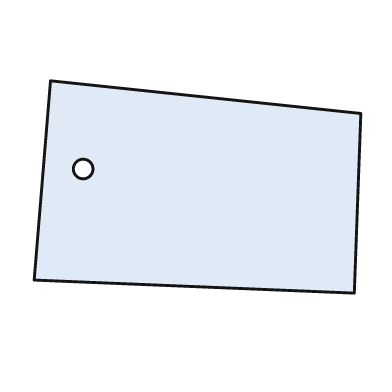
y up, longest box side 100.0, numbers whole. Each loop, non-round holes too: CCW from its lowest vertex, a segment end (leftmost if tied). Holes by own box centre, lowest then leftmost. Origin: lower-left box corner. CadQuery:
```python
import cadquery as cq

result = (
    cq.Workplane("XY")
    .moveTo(98.0, 0.0)
    .lineTo(100.0, 55.0)
    .lineTo(5.0, 65.0)
    .lineTo(0.0, 4.0)
    .close()
    .moveTo(15.0, 38.0)
    .circle(3.0)
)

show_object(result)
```